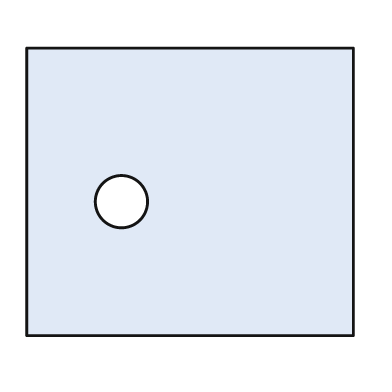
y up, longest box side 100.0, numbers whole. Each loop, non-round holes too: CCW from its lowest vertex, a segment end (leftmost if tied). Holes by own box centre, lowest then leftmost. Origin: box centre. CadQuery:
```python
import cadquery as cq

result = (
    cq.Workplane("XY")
    .moveTo(-50.0, -44.0)
    .lineTo(50.0, -44.0)
    .lineTo(50.0, 44.0)
    .lineTo(-50.0, 44.0)
    .close()
    .moveTo(-21.0, -3.0)
    .circle(8.0)
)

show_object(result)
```